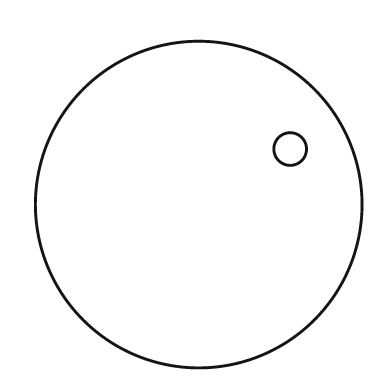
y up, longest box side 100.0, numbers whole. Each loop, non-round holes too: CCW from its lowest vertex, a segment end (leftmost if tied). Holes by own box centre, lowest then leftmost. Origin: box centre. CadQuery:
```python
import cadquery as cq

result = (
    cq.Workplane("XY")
    .moveTo(0.0, 0.0)
    .circle(50.0)
    .moveTo(28.0, 17.0)
    .circle(5.0)
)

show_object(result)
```